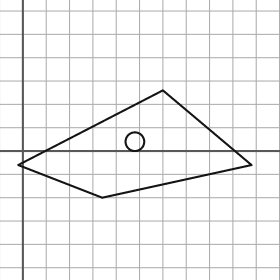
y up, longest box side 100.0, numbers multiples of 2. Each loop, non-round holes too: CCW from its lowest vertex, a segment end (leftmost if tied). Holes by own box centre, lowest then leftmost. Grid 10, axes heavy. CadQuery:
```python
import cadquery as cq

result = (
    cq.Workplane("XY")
    .moveTo(34.0, -20.0)
    .lineTo(98.0, -6.0)
    .lineTo(60.0, 26.0)
    .lineTo(-2.0, -6.0)
    .close()
    .moveTo(48.0, 4.0)
    .circle(4.0)
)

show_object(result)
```